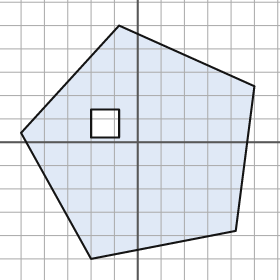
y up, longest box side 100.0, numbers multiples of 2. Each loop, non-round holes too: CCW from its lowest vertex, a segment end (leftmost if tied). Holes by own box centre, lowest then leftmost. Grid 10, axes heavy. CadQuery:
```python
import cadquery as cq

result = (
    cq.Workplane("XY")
    .moveTo(-20.0, -50.0)
    .lineTo(42.0, -38.0)
    .lineTo(50.0, 24.0)
    .lineTo(-8.0, 50.0)
    .lineTo(-50.0, 4.0)
    .close()
    .moveTo(-20.0, 2.0)
    .lineTo(-8.0, 2.0)
    .lineTo(-8.0, 14.0)
    .lineTo(-20.0, 14.0)
    .close()
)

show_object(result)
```